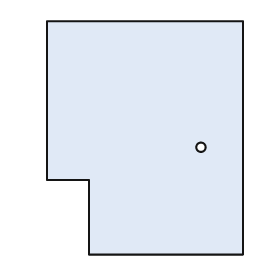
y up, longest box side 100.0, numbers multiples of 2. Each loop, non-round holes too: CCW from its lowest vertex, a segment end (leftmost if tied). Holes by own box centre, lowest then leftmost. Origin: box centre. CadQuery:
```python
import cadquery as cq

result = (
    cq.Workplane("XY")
    .moveTo(-24.0, -50.0)
    .lineTo(42.0, -50.0)
    .lineTo(42.0, 50.0)
    .lineTo(-42.0, 50.0)
    .lineTo(-42.0, -18.0)
    .lineTo(-24.0, -18.0)
    .close()
    .moveTo(24.0, -4.0)
    .circle(2.0)
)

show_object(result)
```